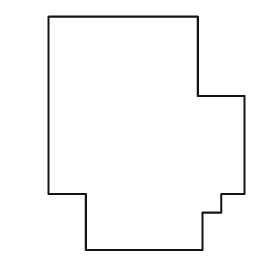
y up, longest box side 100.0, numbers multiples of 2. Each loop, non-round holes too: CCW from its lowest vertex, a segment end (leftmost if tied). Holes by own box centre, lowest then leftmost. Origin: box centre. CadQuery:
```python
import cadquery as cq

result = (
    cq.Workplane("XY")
    .moveTo(-26.0, -50.0)
    .lineTo(24.0, -50.0)
    .lineTo(24.0, -34.0)
    .lineTo(32.0, -34.0)
    .lineTo(32.0, -26.0)
    .lineTo(42.0, -26.0)
    .lineTo(42.0, 16.0)
    .lineTo(22.0, 16.0)
    .lineTo(22.0, 50.0)
    .lineTo(-42.0, 50.0)
    .lineTo(-42.0, -26.0)
    .lineTo(-26.0, -26.0)
    .close()
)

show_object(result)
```